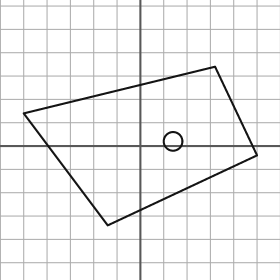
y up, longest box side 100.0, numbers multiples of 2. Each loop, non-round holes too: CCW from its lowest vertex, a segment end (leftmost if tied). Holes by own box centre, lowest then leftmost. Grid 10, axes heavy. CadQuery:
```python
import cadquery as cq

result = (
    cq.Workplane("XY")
    .moveTo(-14.0, -34.0)
    .lineTo(50.0, -4.0)
    .lineTo(32.0, 34.0)
    .lineTo(-50.0, 14.0)
    .close()
    .moveTo(14.0, 2.0)
    .circle(4.0)
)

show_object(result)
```